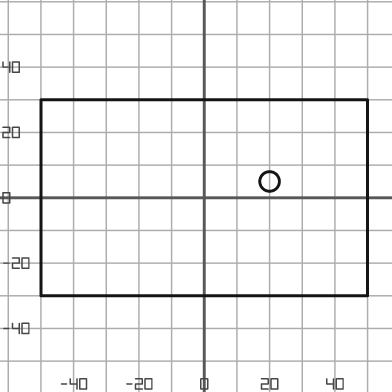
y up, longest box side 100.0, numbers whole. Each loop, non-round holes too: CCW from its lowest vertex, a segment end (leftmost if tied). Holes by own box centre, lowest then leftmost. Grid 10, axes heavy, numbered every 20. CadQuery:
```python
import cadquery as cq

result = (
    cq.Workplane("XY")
    .moveTo(-50.0, -30.0)
    .lineTo(50.0, -30.0)
    .lineTo(50.0, 30.0)
    .lineTo(-50.0, 30.0)
    .close()
    .moveTo(20.0, 5.0)
    .circle(3.0)
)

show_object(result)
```